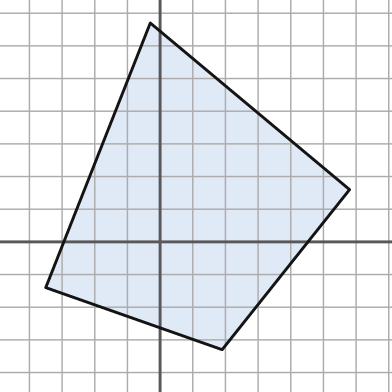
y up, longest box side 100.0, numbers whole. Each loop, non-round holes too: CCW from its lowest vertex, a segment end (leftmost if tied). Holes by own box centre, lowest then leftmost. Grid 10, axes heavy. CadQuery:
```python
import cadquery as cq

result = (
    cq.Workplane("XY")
    .moveTo(19.0, -33.0)
    .lineTo(58.0, 16.0)
    .lineTo(-3.0, 67.0)
    .lineTo(-35.0, -14.0)
    .close()
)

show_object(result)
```